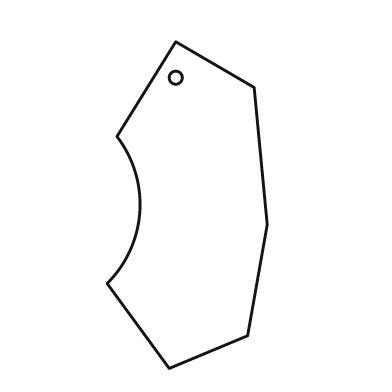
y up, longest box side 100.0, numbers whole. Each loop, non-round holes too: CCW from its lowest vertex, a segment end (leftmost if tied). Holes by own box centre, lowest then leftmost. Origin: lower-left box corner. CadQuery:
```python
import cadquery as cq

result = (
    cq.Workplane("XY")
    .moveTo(19.0, 0.0)
    .lineTo(43.0, 10.0)
    .lineTo(49.0, 44.0)
    .lineTo(45.0, 86.0)
    .lineTo(21.0, 100.0)
    .lineTo(3.0, 71.0)
    .threePointArc((10.0, 48.0), (0.0, 26.0))
    .close()
    .moveTo(21.0, 89.0)
    .circle(2.0)
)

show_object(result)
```